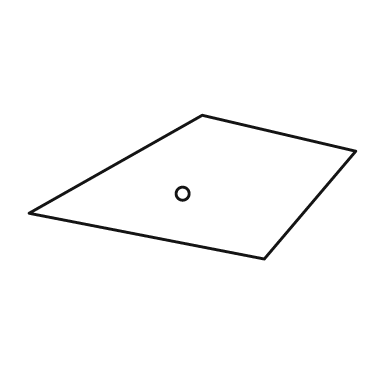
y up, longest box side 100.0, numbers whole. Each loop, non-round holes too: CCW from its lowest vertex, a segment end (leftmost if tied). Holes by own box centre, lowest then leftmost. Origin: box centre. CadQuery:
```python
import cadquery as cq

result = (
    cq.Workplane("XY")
    .moveTo(22.0, -22.0)
    .lineTo(50.0, 11.0)
    .lineTo(3.0, 22.0)
    .lineTo(-50.0, -8.0)
    .close()
    .moveTo(-3.0, -2.0)
    .circle(2.0)
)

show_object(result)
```